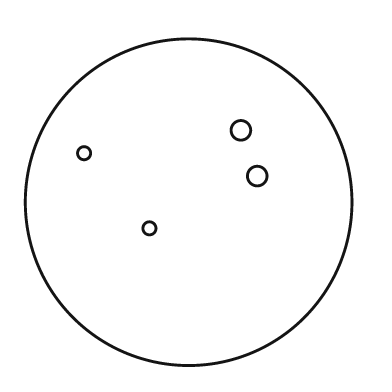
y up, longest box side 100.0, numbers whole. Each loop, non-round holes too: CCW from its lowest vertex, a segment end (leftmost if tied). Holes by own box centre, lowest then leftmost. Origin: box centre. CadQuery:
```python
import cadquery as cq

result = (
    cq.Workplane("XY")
    .moveTo(0.0, 0.0)
    .circle(50.0)
    .moveTo(-12.0, -8.0)
    .circle(2.0)
    .moveTo(21.0, 8.0)
    .circle(3.0)
    .moveTo(-32.0, 15.0)
    .circle(2.0)
    .moveTo(16.0, 22.0)
    .circle(3.0)
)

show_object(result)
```